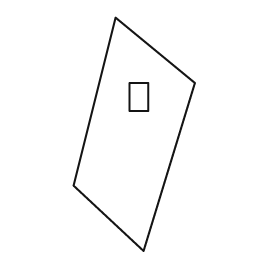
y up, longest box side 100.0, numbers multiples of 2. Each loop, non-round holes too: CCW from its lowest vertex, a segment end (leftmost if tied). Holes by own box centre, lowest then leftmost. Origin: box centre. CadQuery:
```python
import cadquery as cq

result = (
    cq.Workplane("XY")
    .moveTo(4.0, -50.0)
    .lineTo(26.0, 22.0)
    .lineTo(-8.0, 50.0)
    .lineTo(-26.0, -22.0)
    .close()
    .moveTo(-2.0, 10.0)
    .lineTo(6.0, 10.0)
    .lineTo(6.0, 22.0)
    .lineTo(-2.0, 22.0)
    .close()
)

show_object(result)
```